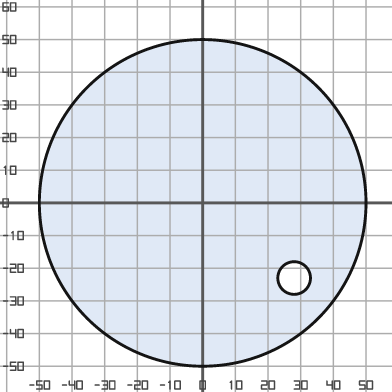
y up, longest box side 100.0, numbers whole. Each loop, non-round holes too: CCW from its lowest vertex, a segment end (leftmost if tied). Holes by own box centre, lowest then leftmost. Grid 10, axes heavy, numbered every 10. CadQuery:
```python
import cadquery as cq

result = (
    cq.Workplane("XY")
    .moveTo(0.0, 0.0)
    .circle(50.0)
    .moveTo(28.0, -23.0)
    .circle(5.0)
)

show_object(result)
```